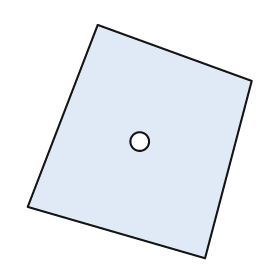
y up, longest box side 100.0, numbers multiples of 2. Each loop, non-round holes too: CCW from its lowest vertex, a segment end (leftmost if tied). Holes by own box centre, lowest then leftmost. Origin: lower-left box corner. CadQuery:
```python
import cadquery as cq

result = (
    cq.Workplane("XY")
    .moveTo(76.0, 0.0)
    .lineTo(96.0, 76.0)
    .lineTo(30.0, 100.0)
    .lineTo(0.0, 22.0)
    .close()
    .moveTo(48.0, 50.0)
    .circle(4.0)
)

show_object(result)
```